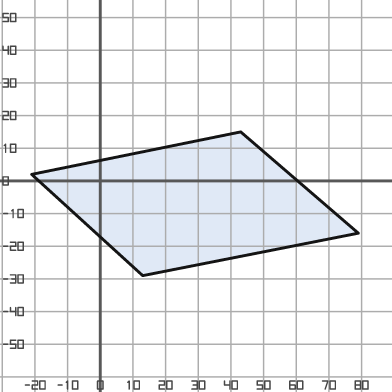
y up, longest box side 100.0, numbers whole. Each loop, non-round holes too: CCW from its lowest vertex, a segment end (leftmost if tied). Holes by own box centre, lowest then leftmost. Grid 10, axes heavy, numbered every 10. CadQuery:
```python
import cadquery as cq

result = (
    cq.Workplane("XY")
    .moveTo(13.0, -29.0)
    .lineTo(79.0, -16.0)
    .lineTo(43.0, 15.0)
    .lineTo(-21.0, 2.0)
    .close()
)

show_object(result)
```